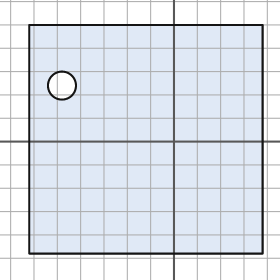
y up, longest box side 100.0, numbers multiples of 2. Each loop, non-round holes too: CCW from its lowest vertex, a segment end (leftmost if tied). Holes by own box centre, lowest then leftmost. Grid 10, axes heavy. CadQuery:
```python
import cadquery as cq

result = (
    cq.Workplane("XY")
    .moveTo(-62.0, -48.0)
    .lineTo(38.0, -48.0)
    .lineTo(38.0, 50.0)
    .lineTo(-62.0, 50.0)
    .close()
    .moveTo(-48.0, 24.0)
    .circle(6.0)
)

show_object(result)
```